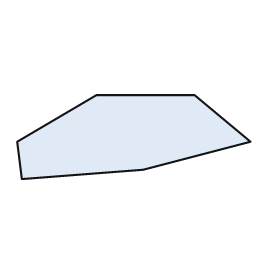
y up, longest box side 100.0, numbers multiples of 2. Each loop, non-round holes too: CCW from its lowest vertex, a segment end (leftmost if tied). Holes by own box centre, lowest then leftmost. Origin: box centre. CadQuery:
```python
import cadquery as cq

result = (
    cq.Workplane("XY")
    .moveTo(-48.0, -18.0)
    .lineTo(4.0, -14.0)
    .lineTo(50.0, -2.0)
    .lineTo(26.0, 18.0)
    .lineTo(-16.0, 18.0)
    .lineTo(-50.0, -2.0)
    .close()
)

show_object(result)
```